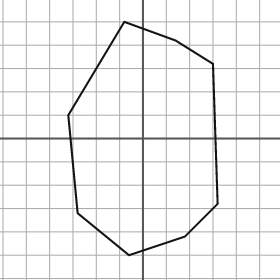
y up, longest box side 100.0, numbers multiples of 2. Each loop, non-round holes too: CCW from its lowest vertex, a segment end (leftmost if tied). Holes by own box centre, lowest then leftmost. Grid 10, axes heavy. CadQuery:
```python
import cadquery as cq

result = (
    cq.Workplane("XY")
    .moveTo(-6.0, -50.0)
    .lineTo(18.0, -42.0)
    .lineTo(32.0, -28.0)
    .lineTo(30.0, 32.0)
    .lineTo(14.0, 42.0)
    .lineTo(-8.0, 50.0)
    .lineTo(-32.0, 10.0)
    .lineTo(-28.0, -32.0)
    .close()
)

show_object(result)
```